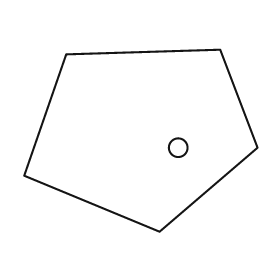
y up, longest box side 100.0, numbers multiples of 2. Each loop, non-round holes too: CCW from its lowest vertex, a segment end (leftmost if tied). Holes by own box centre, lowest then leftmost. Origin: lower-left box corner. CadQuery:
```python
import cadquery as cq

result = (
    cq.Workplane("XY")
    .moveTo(58.0, 0.0)
    .lineTo(100.0, 36.0)
    .lineTo(84.0, 78.0)
    .lineTo(18.0, 76.0)
    .lineTo(0.0, 24.0)
    .close()
    .moveTo(66.0, 36.0)
    .circle(4.0)
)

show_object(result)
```